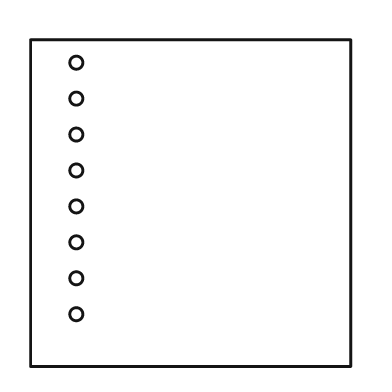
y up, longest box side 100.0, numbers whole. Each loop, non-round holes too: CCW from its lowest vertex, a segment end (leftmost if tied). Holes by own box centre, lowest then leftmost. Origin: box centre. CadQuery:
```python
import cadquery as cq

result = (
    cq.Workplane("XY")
    .moveTo(-49.0, -50.0)
    .lineTo(49.0, -50.0)
    .lineTo(49.0, 50.0)
    .lineTo(-49.0, 50.0)
    .close()
    .moveTo(-35.0, -34.0)
    .circle(2.0)
    .moveTo(-35.0, -23.0)
    .circle(2.0)
    .moveTo(-35.0, -12.0)
    .circle(2.0)
    .moveTo(-35.0, -1.0)
    .circle(2.0)
    .moveTo(-35.0, 10.0)
    .circle(2.0)
    .moveTo(-35.0, 21.0)
    .circle(2.0)
    .moveTo(-35.0, 32.0)
    .circle(2.0)
    .moveTo(-35.0, 43.0)
    .circle(2.0)
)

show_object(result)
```